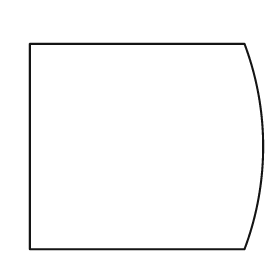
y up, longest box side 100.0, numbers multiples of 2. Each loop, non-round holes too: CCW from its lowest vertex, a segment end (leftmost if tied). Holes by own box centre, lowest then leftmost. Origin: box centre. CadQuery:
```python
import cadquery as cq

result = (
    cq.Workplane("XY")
    .moveTo(-50.0, -44.0)
    .lineTo(42.0, -44.0)
    .threePointArc((50.0, 0.0), (42.0, 44.0))
    .lineTo(-50.0, 44.0)
    .close()
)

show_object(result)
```